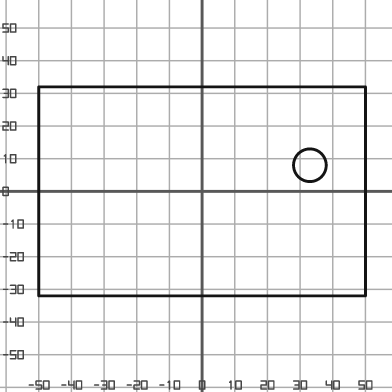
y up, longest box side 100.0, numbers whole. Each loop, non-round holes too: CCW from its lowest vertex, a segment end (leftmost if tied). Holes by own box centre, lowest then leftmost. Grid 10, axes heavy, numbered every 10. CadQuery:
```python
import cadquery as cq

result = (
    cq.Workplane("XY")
    .moveTo(-50.0, -32.0)
    .lineTo(50.0, -32.0)
    .lineTo(50.0, 32.0)
    .lineTo(-50.0, 32.0)
    .close()
    .moveTo(33.0, 8.0)
    .circle(5.0)
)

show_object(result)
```